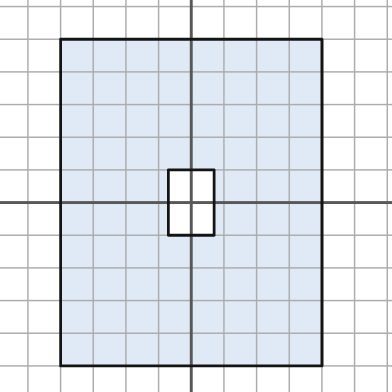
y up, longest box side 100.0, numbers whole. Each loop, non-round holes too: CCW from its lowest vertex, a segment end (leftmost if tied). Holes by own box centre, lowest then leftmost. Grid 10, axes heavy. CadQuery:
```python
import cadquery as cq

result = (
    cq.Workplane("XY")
    .moveTo(-40.0, -50.0)
    .lineTo(40.0, -50.0)
    .lineTo(40.0, 50.0)
    .lineTo(-40.0, 50.0)
    .close()
    .moveTo(-7.0, -10.0)
    .lineTo(7.0, -10.0)
    .lineTo(7.0, 10.0)
    .lineTo(-7.0, 10.0)
    .close()
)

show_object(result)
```